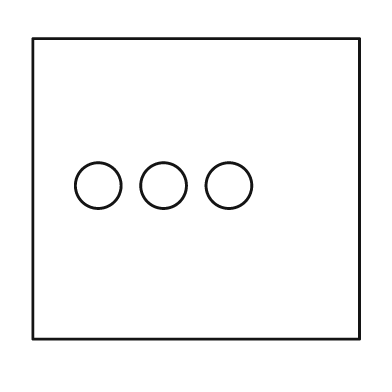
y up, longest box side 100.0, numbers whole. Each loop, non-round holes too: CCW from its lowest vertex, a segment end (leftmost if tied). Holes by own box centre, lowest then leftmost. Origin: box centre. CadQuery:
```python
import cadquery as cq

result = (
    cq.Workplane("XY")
    .moveTo(-50.0, -46.0)
    .lineTo(50.0, -46.0)
    .lineTo(50.0, 46.0)
    .lineTo(-50.0, 46.0)
    .close()
    .moveTo(-30.0, 1.0)
    .circle(7.0)
    .moveTo(-10.0, 1.0)
    .circle(7.0)
    .moveTo(10.0, 1.0)
    .circle(7.0)
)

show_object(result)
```